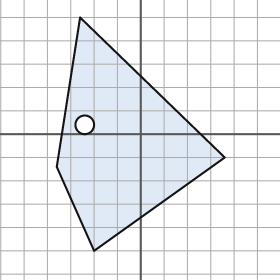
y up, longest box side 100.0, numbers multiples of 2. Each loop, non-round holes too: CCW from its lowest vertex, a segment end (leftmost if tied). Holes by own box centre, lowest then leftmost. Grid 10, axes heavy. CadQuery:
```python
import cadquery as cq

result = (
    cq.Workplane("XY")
    .moveTo(-20.0, -50.0)
    .lineTo(36.0, -10.0)
    .lineTo(-26.0, 50.0)
    .lineTo(-36.0, -14.0)
    .close()
    .moveTo(-24.0, 4.0)
    .circle(4.0)
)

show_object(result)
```